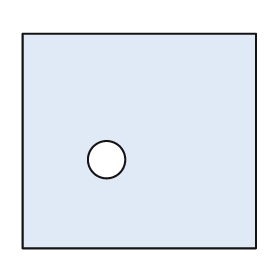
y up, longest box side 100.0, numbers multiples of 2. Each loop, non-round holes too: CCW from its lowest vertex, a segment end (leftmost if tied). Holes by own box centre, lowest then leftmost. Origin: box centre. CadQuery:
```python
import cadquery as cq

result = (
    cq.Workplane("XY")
    .moveTo(-50.0, -46.0)
    .lineTo(50.0, -46.0)
    .lineTo(50.0, 46.0)
    .lineTo(-50.0, 46.0)
    .close()
    .moveTo(-14.0, -8.0)
    .circle(8.0)
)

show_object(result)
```